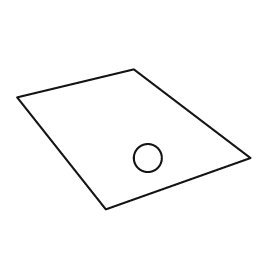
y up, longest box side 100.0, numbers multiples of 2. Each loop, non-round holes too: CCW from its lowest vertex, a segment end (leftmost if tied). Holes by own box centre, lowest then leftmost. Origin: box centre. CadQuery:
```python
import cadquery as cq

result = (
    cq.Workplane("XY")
    .moveTo(-12.0, -30.0)
    .lineTo(50.0, -8.0)
    .lineTo(0.0, 30.0)
    .lineTo(-50.0, 18.0)
    .close()
    .moveTo(6.0, -8.0)
    .circle(6.0)
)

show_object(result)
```